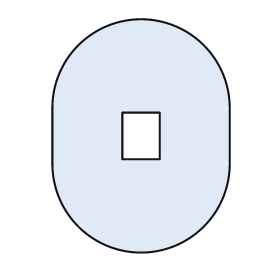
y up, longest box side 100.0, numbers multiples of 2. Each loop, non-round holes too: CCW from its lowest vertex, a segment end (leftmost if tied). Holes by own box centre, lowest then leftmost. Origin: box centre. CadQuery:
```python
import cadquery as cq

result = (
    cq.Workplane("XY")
    .moveTo(-38.0, -12.0)
    .threePointArc((0.0, -50.0), (38.0, -12.0))
    .lineTo(38.0, 12.0)
    .threePointArc((0.0, 50.0), (-38.0, 12.0))
    .close()
    .moveTo(-8.0, -10.0)
    .lineTo(8.0, -10.0)
    .lineTo(8.0, 10.0)
    .lineTo(-8.0, 10.0)
    .close()
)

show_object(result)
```